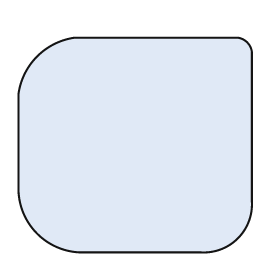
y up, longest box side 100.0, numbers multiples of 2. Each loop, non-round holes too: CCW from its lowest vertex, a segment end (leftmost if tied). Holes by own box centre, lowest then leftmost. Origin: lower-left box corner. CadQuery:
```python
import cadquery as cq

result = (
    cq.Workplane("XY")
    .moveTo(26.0, 0.0)
    .lineTo(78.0, 0.0)
    .threePointArc((94.0, 6.0), (100.0, 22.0))
    .lineTo(100.0, 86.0)
    .threePointArc((98.0, 90.0), (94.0, 92.0))
    .lineTo(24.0, 92.0)
    .threePointArc((8.0, 84.0), (0.0, 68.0))
    .lineTo(0.0, 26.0)
    .threePointArc((8.0, 8.0), (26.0, 0.0))
    .close()
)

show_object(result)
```